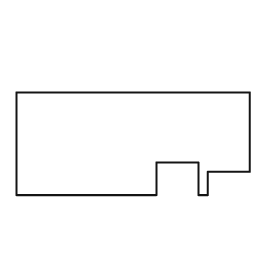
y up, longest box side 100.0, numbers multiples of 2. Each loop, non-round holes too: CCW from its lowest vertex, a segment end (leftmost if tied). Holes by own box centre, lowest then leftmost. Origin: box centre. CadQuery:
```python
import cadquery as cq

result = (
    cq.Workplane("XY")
    .moveTo(-50.0, -22.0)
    .lineTo(10.0, -22.0)
    .lineTo(10.0, -8.0)
    .lineTo(28.0, -8.0)
    .lineTo(28.0, -22.0)
    .lineTo(32.0, -22.0)
    .lineTo(32.0, -12.0)
    .lineTo(50.0, -12.0)
    .lineTo(50.0, 22.0)
    .lineTo(-50.0, 22.0)
    .close()
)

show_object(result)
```